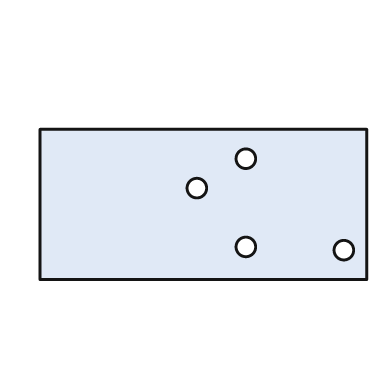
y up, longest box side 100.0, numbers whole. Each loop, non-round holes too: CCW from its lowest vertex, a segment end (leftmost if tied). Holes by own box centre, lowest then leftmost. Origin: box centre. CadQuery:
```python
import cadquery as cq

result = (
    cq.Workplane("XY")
    .moveTo(-50.0, -23.0)
    .lineTo(50.0, -23.0)
    .lineTo(50.0, 23.0)
    .lineTo(-50.0, 23.0)
    .close()
    .moveTo(43.0, -14.0)
    .circle(3.0)
    .moveTo(13.0, -13.0)
    .circle(3.0)
    .moveTo(-2.0, 5.0)
    .circle(3.0)
    .moveTo(13.0, 14.0)
    .circle(3.0)
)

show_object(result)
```